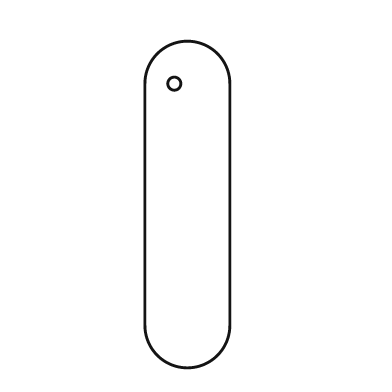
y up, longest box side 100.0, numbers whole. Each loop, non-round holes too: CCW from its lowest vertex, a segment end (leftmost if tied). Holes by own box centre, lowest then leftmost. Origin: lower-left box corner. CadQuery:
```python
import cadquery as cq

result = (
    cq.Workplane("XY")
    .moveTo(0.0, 13.0)
    .threePointArc((13.0, 0.0), (26.0, 13.0))
    .lineTo(26.0, 87.0)
    .threePointArc((13.0, 100.0), (0.0, 87.0))
    .close()
    .moveTo(9.0, 87.0)
    .circle(2.0)
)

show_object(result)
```